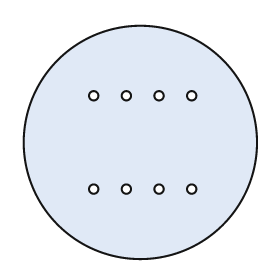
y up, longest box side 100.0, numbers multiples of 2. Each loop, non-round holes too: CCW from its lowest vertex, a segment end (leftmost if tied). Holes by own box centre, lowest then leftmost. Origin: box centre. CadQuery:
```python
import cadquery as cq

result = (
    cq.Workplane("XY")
    .moveTo(0.0, 0.0)
    .circle(50.0)
    .moveTo(-20.0, -20.0)
    .circle(2.0)
    .moveTo(-6.0, -20.0)
    .circle(2.0)
    .moveTo(8.0, -20.0)
    .circle(2.0)
    .moveTo(22.0, -20.0)
    .circle(2.0)
    .moveTo(-20.0, 20.0)
    .circle(2.0)
    .moveTo(-6.0, 20.0)
    .circle(2.0)
    .moveTo(8.0, 20.0)
    .circle(2.0)
    .moveTo(22.0, 20.0)
    .circle(2.0)
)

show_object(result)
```